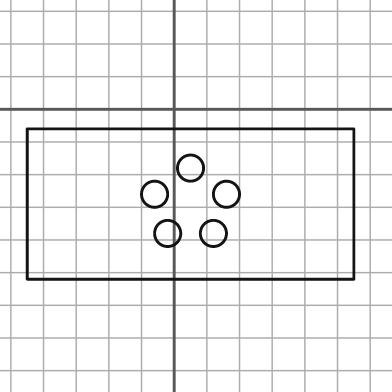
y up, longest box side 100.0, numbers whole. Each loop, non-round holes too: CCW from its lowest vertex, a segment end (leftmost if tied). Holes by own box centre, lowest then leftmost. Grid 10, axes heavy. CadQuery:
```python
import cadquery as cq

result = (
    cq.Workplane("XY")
    .moveTo(-45.0, -52.0)
    .lineTo(55.0, -52.0)
    .lineTo(55.0, -6.0)
    .lineTo(-45.0, -6.0)
    .close()
    .moveTo(-2.0, -38.0)
    .circle(4.0)
    .moveTo(12.0, -38.0)
    .circle(4.0)
    .moveTo(-6.0, -26.0)
    .circle(4.0)
    .moveTo(16.0, -26.0)
    .circle(4.0)
    .moveTo(5.0, -18.0)
    .circle(4.0)
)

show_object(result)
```